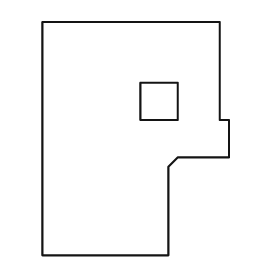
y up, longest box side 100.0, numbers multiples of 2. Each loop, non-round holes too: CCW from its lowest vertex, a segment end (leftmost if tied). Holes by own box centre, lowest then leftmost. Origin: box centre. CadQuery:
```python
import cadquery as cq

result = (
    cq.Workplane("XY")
    .moveTo(-40.0, -50.0)
    .lineTo(14.0, -50.0)
    .lineTo(14.0, -12.0)
    .lineTo(18.0, -8.0)
    .lineTo(40.0, -8.0)
    .lineTo(40.0, 8.0)
    .lineTo(36.0, 8.0)
    .lineTo(36.0, 50.0)
    .lineTo(-40.0, 50.0)
    .close()
    .moveTo(2.0, 8.0)
    .lineTo(18.0, 8.0)
    .lineTo(18.0, 24.0)
    .lineTo(2.0, 24.0)
    .close()
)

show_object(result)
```